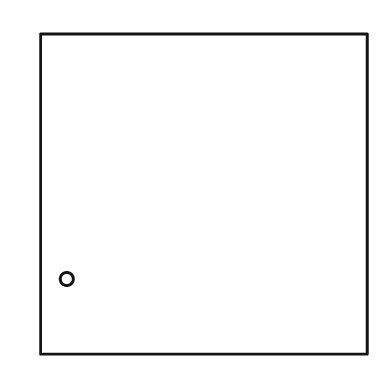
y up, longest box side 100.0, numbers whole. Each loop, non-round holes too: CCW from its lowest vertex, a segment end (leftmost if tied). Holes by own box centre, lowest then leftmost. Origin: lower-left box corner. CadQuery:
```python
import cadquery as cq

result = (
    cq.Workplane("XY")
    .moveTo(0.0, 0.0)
    .lineTo(100.0, 0.0)
    .lineTo(100.0, 98.0)
    .lineTo(0.0, 98.0)
    .close()
    .moveTo(8.0, 23.0)
    .circle(2.0)
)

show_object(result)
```